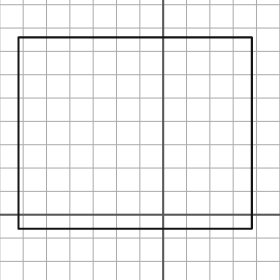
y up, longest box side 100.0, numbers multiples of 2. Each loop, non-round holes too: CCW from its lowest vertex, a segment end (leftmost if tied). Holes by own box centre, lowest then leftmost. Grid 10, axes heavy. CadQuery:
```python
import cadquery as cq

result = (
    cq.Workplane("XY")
    .moveTo(-62.0, -6.0)
    .lineTo(38.0, -6.0)
    .lineTo(38.0, 76.0)
    .lineTo(-62.0, 76.0)
    .close()
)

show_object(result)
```